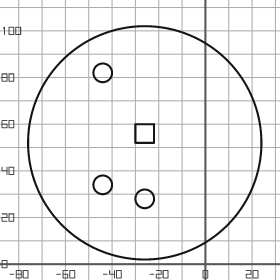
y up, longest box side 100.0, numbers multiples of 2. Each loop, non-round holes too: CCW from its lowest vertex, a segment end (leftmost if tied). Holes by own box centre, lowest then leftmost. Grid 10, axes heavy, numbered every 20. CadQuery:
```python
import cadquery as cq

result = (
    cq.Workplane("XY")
    .moveTo(-26.0, 52.0)
    .circle(50.0)
    .moveTo(-26.0, 28.0)
    .circle(4.0)
    .moveTo(-44.0, 34.0)
    .circle(4.0)
    .moveTo(-30.0, 52.0)
    .lineTo(-22.0, 52.0)
    .lineTo(-22.0, 60.0)
    .lineTo(-30.0, 60.0)
    .close()
    .moveTo(-44.0, 82.0)
    .circle(4.0)
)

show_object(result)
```